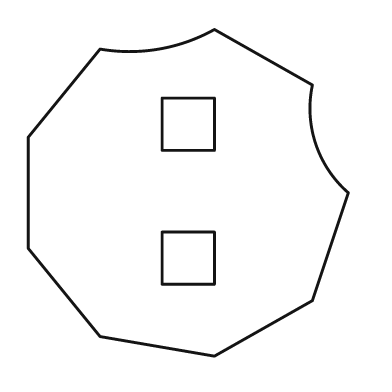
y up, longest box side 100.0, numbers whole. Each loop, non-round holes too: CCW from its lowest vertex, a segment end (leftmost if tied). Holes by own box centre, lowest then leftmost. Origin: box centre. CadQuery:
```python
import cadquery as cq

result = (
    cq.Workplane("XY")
    .moveTo(8.0, -50.0)
    .lineTo(38.0, -33.0)
    .lineTo(49.0, 0.0)
    .threePointArc((39.0, 15.0), (38.0, 33.0))
    .lineTo(8.0, 50.0)
    .threePointArc((-9.0, 44.0), (-27.0, 44.0))
    .lineTo(-49.0, 17.0)
    .lineTo(-49.0, -17.0)
    .lineTo(-27.0, -44.0)
    .close()
    .moveTo(-8.0, -28.0)
    .lineTo(8.0, -28.0)
    .lineTo(8.0, -12.0)
    .lineTo(-8.0, -12.0)
    .close()
    .moveTo(-8.0, 13.0)
    .lineTo(8.0, 13.0)
    .lineTo(8.0, 29.0)
    .lineTo(-8.0, 29.0)
    .close()
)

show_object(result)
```